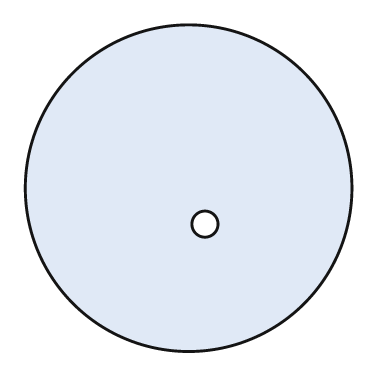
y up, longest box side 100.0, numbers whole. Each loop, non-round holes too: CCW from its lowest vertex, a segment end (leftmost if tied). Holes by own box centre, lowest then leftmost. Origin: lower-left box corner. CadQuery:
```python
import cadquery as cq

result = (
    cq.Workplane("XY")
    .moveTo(50.0, 50.0)
    .circle(50.0)
    .moveTo(55.0, 39.0)
    .circle(4.0)
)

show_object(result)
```